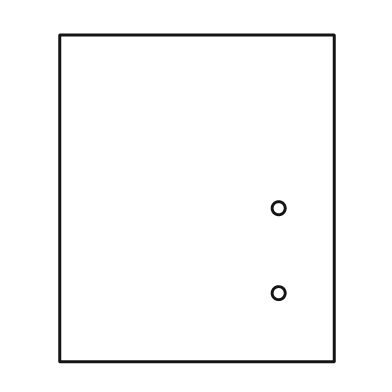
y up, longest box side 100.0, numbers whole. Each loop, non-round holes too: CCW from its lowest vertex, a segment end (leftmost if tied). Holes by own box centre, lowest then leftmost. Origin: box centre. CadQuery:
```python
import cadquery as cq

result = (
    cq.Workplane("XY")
    .moveTo(-42.0, -50.0)
    .lineTo(42.0, -50.0)
    .lineTo(42.0, 50.0)
    .lineTo(-42.0, 50.0)
    .close()
    .moveTo(25.0, -29.0)
    .circle(2.0)
    .moveTo(25.0, -3.0)
    .circle(2.0)
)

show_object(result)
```